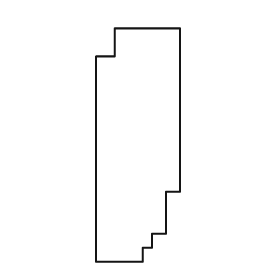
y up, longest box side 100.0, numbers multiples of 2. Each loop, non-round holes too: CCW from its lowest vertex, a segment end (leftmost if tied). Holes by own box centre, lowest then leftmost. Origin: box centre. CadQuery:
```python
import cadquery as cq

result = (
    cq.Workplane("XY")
    .moveTo(-18.0, -50.0)
    .lineTo(2.0, -50.0)
    .lineTo(2.0, -44.0)
    .lineTo(6.0, -44.0)
    .lineTo(6.0, -38.0)
    .lineTo(12.0, -38.0)
    .lineTo(12.0, -20.0)
    .lineTo(18.0, -20.0)
    .lineTo(18.0, 50.0)
    .lineTo(-10.0, 50.0)
    .lineTo(-10.0, 38.0)
    .lineTo(-18.0, 38.0)
    .close()
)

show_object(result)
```